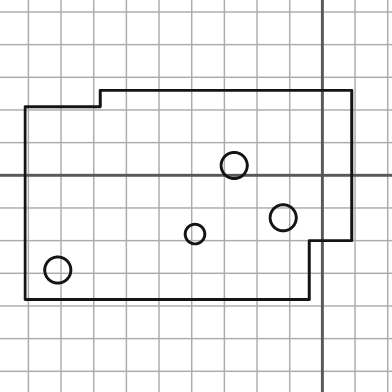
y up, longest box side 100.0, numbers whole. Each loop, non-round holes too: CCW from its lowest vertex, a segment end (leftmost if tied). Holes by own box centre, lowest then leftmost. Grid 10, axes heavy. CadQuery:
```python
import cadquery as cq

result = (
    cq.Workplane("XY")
    .moveTo(-91.0, -38.0)
    .lineTo(-4.0, -38.0)
    .lineTo(-4.0, -20.0)
    .lineTo(9.0, -20.0)
    .lineTo(9.0, 26.0)
    .lineTo(-68.0, 26.0)
    .lineTo(-68.0, 21.0)
    .lineTo(-91.0, 21.0)
    .close()
    .moveTo(-81.0, -29.0)
    .circle(4.0)
    .moveTo(-39.0, -18.0)
    .circle(3.0)
    .moveTo(-12.0, -13.0)
    .circle(4.0)
    .moveTo(-27.0, 3.0)
    .circle(4.0)
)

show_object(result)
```